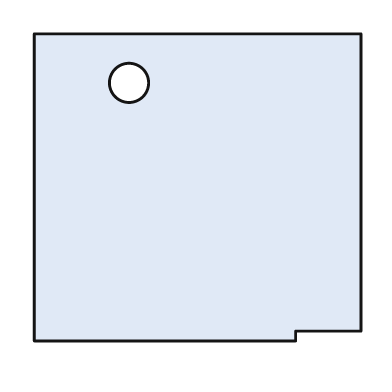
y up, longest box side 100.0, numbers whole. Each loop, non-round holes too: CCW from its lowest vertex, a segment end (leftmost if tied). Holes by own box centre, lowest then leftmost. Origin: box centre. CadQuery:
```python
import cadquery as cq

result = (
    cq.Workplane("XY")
    .moveTo(-50.0, -47.0)
    .lineTo(30.0, -47.0)
    .lineTo(30.0, -44.0)
    .lineTo(50.0, -44.0)
    .lineTo(50.0, 47.0)
    .lineTo(-50.0, 47.0)
    .close()
    .moveTo(-21.0, 32.0)
    .circle(6.0)
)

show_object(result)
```